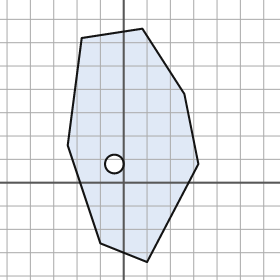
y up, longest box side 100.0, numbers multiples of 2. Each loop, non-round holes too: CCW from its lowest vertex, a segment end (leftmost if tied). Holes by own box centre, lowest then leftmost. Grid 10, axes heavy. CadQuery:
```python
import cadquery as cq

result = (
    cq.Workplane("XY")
    .moveTo(10.0, -34.0)
    .lineTo(32.0, 8.0)
    .lineTo(26.0, 38.0)
    .lineTo(8.0, 66.0)
    .lineTo(-18.0, 62.0)
    .lineTo(-24.0, 16.0)
    .lineTo(-10.0, -26.0)
    .close()
    .moveTo(-4.0, 8.0)
    .circle(4.0)
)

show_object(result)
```